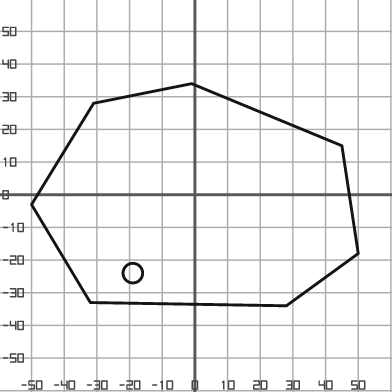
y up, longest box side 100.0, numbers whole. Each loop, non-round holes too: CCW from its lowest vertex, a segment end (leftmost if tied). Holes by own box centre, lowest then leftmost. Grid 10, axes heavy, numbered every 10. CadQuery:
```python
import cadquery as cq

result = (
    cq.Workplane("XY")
    .moveTo(28.0, -34.0)
    .lineTo(50.0, -18.0)
    .lineTo(45.0, 15.0)
    .lineTo(-1.0, 34.0)
    .lineTo(-31.0, 28.0)
    .lineTo(-50.0, -3.0)
    .lineTo(-32.0, -33.0)
    .close()
    .moveTo(-19.0, -24.0)
    .circle(3.0)
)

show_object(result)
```